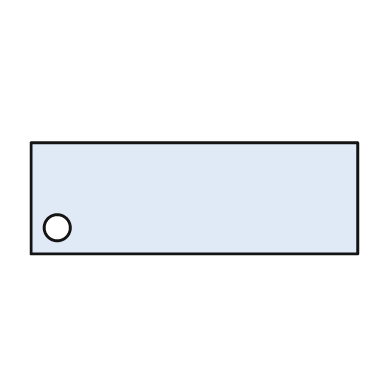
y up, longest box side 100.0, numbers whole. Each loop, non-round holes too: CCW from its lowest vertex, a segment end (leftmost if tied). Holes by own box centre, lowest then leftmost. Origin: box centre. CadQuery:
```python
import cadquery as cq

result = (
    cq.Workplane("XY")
    .moveTo(-50.0, -17.0)
    .lineTo(50.0, -17.0)
    .lineTo(50.0, 17.0)
    .lineTo(-50.0, 17.0)
    .close()
    .moveTo(-42.0, -9.0)
    .circle(4.0)
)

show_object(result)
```